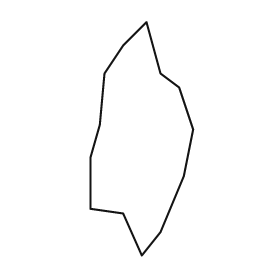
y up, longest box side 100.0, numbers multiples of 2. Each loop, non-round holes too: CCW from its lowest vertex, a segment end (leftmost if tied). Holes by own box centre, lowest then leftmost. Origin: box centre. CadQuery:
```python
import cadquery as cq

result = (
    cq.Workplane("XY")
    .moveTo(0.0, -50.0)
    .lineTo(8.0, -40.0)
    .lineTo(18.0, -16.0)
    .lineTo(22.0, 4.0)
    .lineTo(16.0, 22.0)
    .lineTo(8.0, 28.0)
    .lineTo(2.0, 50.0)
    .lineTo(-8.0, 40.0)
    .lineTo(-16.0, 28.0)
    .lineTo(-18.0, 6.0)
    .lineTo(-22.0, -8.0)
    .lineTo(-22.0, -30.0)
    .lineTo(-8.0, -32.0)
    .close()
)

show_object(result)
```